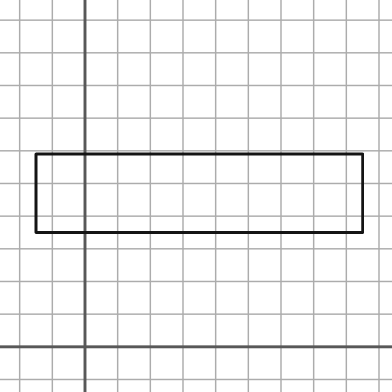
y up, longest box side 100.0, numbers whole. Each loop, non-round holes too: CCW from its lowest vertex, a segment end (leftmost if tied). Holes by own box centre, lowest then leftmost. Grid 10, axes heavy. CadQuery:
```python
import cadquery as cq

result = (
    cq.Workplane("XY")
    .moveTo(-15.0, 35.0)
    .lineTo(85.0, 35.0)
    .lineTo(85.0, 59.0)
    .lineTo(-15.0, 59.0)
    .close()
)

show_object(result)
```